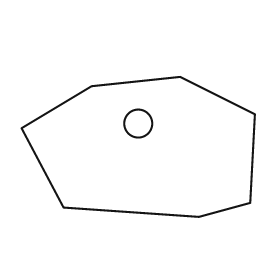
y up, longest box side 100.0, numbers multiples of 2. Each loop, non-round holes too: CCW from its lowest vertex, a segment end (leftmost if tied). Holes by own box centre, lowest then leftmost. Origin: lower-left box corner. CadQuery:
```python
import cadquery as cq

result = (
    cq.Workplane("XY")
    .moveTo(76.0, 0.0)
    .lineTo(98.0, 6.0)
    .lineTo(100.0, 44.0)
    .lineTo(68.0, 60.0)
    .lineTo(30.0, 56.0)
    .lineTo(0.0, 38.0)
    .lineTo(18.0, 4.0)
    .close()
    .moveTo(50.0, 40.0)
    .circle(6.0)
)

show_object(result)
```